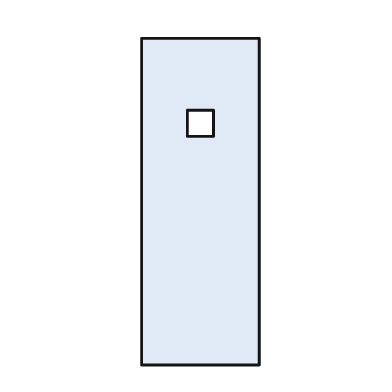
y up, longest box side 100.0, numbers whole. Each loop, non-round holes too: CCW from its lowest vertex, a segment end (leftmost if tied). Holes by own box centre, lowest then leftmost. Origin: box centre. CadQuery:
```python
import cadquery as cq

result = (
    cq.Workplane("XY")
    .moveTo(-18.0, -50.0)
    .lineTo(18.0, -50.0)
    .lineTo(18.0, 50.0)
    .lineTo(-18.0, 50.0)
    .close()
    .moveTo(-4.0, 20.0)
    .lineTo(4.0, 20.0)
    .lineTo(4.0, 28.0)
    .lineTo(-4.0, 28.0)
    .close()
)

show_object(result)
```